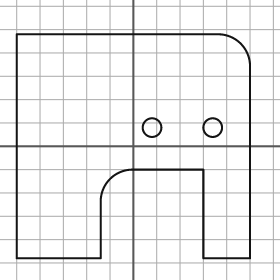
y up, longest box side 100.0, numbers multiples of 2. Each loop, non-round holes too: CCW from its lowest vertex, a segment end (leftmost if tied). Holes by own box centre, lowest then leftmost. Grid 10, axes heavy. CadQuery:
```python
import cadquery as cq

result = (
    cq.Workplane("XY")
    .moveTo(-50.0, -48.0)
    .lineTo(-14.0, -48.0)
    .lineTo(-14.0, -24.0)
    .threePointArc((-10.0, -14.0), (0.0, -10.0))
    .lineTo(30.0, -10.0)
    .lineTo(30.0, -48.0)
    .lineTo(50.0, -48.0)
    .lineTo(50.0, 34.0)
    .threePointArc((46.0, 44.0), (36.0, 48.0))
    .lineTo(-50.0, 48.0)
    .close()
    .moveTo(8.0, 8.0)
    .circle(4.0)
    .moveTo(34.0, 8.0)
    .circle(4.0)
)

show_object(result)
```